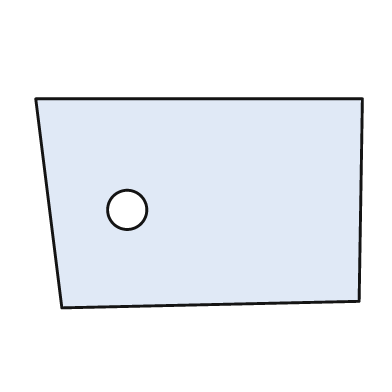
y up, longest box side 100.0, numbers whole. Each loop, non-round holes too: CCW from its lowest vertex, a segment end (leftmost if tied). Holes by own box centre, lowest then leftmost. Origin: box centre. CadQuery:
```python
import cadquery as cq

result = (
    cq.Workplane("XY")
    .moveTo(-42.0, -32.0)
    .lineTo(49.0, -30.0)
    .lineTo(50.0, 32.0)
    .lineTo(-50.0, 32.0)
    .close()
    .moveTo(-22.0, -2.0)
    .circle(6.0)
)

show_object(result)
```